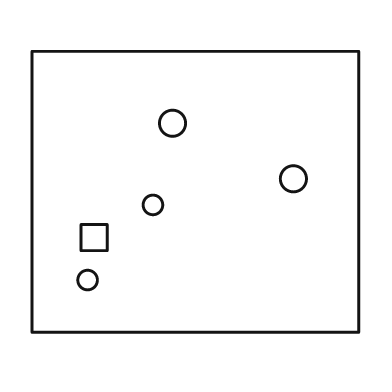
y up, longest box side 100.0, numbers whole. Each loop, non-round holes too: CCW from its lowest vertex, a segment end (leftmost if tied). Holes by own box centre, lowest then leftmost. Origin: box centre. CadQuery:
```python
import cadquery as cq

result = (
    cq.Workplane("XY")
    .moveTo(-50.0, -43.0)
    .lineTo(50.0, -43.0)
    .lineTo(50.0, 43.0)
    .lineTo(-50.0, 43.0)
    .close()
    .moveTo(-33.0, -27.0)
    .circle(3.0)
    .moveTo(-35.0, -18.0)
    .lineTo(-27.0, -18.0)
    .lineTo(-27.0, -10.0)
    .lineTo(-35.0, -10.0)
    .close()
    .moveTo(-13.0, -4.0)
    .circle(3.0)
    .moveTo(30.0, 4.0)
    .circle(4.0)
    .moveTo(-7.0, 21.0)
    .circle(4.0)
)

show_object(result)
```